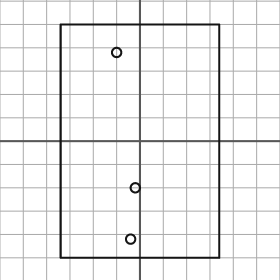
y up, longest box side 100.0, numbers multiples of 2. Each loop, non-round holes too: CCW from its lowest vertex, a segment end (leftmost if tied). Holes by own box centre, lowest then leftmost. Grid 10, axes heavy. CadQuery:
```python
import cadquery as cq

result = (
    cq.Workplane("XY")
    .moveTo(-34.0, -50.0)
    .lineTo(34.0, -50.0)
    .lineTo(34.0, 50.0)
    .lineTo(-34.0, 50.0)
    .close()
    .moveTo(-4.0, -42.0)
    .circle(2.0)
    .moveTo(-2.0, -20.0)
    .circle(2.0)
    .moveTo(-10.0, 38.0)
    .circle(2.0)
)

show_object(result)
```